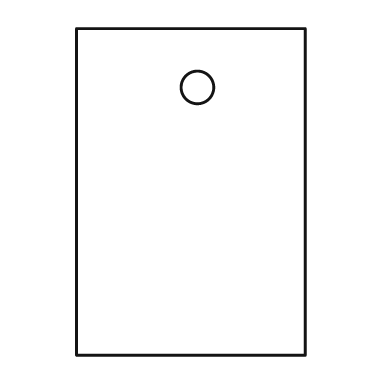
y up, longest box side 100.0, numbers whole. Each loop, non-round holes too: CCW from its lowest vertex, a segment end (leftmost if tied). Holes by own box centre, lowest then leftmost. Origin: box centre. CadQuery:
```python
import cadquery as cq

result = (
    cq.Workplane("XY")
    .moveTo(-35.0, -50.0)
    .lineTo(35.0, -50.0)
    .lineTo(35.0, 50.0)
    .lineTo(-35.0, 50.0)
    .close()
    .moveTo(2.0, 32.0)
    .circle(5.0)
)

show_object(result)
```